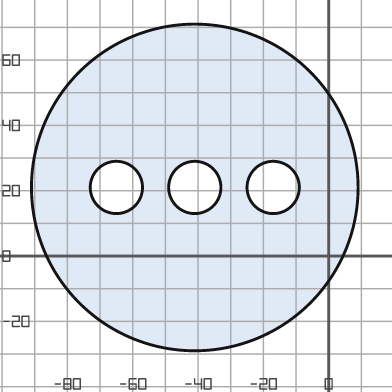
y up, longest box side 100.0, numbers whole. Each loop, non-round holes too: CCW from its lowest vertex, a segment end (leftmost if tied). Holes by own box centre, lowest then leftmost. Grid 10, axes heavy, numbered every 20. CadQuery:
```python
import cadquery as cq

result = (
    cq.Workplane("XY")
    .moveTo(-41.0, 21.0)
    .circle(50.0)
    .moveTo(-65.0, 21.0)
    .circle(8.0)
    .moveTo(-41.0, 21.0)
    .circle(8.0)
    .moveTo(-17.0, 21.0)
    .circle(8.0)
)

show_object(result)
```